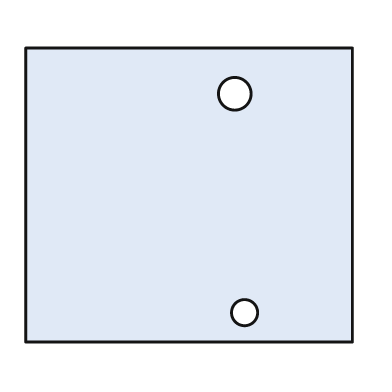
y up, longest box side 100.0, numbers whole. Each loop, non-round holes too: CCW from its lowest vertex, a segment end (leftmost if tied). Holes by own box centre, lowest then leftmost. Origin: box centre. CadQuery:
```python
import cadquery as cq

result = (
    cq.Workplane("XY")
    .moveTo(-50.0, -45.0)
    .lineTo(50.0, -45.0)
    .lineTo(50.0, 45.0)
    .lineTo(-50.0, 45.0)
    .close()
    .moveTo(17.0, -36.0)
    .circle(4.0)
    .moveTo(14.0, 31.0)
    .circle(5.0)
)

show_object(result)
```